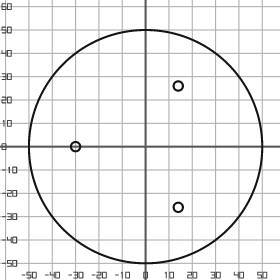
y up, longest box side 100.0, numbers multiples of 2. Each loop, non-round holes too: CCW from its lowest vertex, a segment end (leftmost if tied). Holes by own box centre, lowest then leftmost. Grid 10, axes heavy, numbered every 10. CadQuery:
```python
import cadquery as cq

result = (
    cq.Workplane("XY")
    .moveTo(0.0, 0.0)
    .circle(50.0)
    .moveTo(14.0, -26.0)
    .circle(2.0)
    .moveTo(-30.0, 0.0)
    .circle(2.0)
    .moveTo(14.0, 26.0)
    .circle(2.0)
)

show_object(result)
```